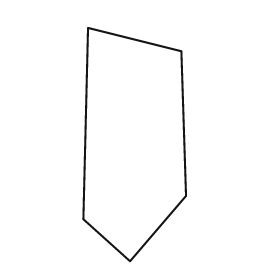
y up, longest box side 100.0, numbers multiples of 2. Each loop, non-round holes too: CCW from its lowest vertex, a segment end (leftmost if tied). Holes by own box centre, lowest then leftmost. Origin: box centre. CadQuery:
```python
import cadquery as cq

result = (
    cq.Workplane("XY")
    .moveTo(-2.0, -50.0)
    .lineTo(22.0, -22.0)
    .lineTo(20.0, 40.0)
    .lineTo(-20.0, 50.0)
    .lineTo(-22.0, -32.0)
    .close()
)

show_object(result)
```